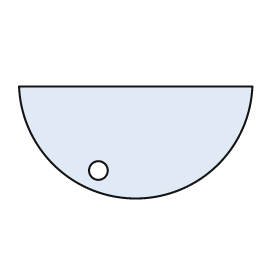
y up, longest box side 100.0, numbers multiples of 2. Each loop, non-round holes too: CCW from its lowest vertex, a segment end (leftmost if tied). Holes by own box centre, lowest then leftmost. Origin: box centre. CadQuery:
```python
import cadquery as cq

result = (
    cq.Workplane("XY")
    .moveTo(-50.0, 24.0)
    .threePointArc((0.0, -24.0), (50.0, 24.0))
    .close()
    .moveTo(-16.0, -12.0)
    .circle(4.0)
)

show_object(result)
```